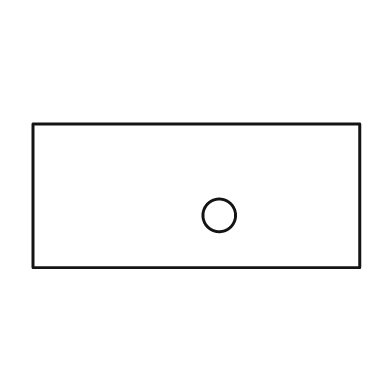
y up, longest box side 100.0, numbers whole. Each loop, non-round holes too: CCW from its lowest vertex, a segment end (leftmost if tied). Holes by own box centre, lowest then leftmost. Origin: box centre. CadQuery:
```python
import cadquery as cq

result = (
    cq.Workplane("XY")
    .moveTo(-50.0, -22.0)
    .lineTo(50.0, -22.0)
    .lineTo(50.0, 22.0)
    .lineTo(-50.0, 22.0)
    .close()
    .moveTo(7.0, -6.0)
    .circle(5.0)
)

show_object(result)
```